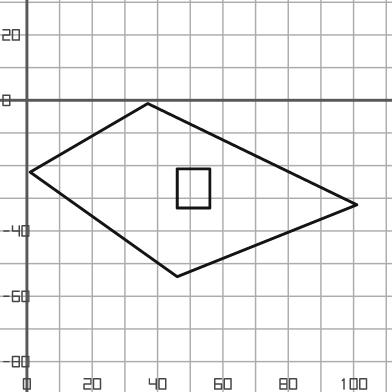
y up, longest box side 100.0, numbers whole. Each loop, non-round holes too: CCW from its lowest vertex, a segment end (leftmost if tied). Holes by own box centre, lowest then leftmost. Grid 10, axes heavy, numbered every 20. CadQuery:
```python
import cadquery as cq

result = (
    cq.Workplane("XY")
    .moveTo(46.0, -54.0)
    .lineTo(101.0, -32.0)
    .lineTo(37.0, -1.0)
    .lineTo(1.0, -22.0)
    .close()
    .moveTo(46.0, -33.0)
    .lineTo(56.0, -33.0)
    .lineTo(56.0, -21.0)
    .lineTo(46.0, -21.0)
    .close()
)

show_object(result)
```